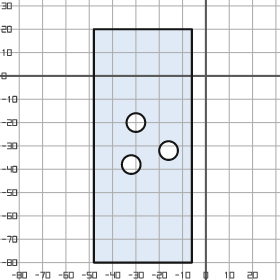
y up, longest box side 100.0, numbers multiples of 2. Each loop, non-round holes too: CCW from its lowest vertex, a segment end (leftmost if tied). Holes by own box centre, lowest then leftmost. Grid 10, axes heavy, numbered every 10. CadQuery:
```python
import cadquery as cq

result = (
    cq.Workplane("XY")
    .moveTo(-48.0, -80.0)
    .lineTo(-6.0, -80.0)
    .lineTo(-6.0, 20.0)
    .lineTo(-48.0, 20.0)
    .close()
    .moveTo(-32.0, -38.0)
    .circle(4.0)
    .moveTo(-16.0, -32.0)
    .circle(4.0)
    .moveTo(-30.0, -20.0)
    .circle(4.0)
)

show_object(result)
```